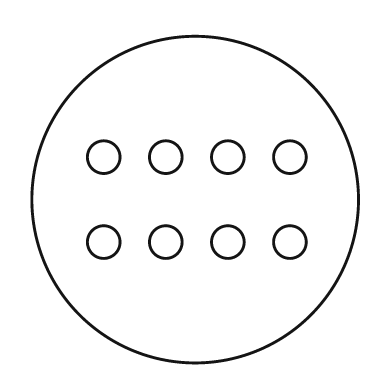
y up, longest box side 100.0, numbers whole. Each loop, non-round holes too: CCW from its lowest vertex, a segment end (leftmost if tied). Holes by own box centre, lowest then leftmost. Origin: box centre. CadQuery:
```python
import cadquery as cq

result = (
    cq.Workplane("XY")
    .moveTo(0.0, 0.0)
    .circle(50.0)
    .moveTo(-28.0, -13.0)
    .circle(5.0)
    .moveTo(-9.0, -13.0)
    .circle(5.0)
    .moveTo(10.0, -13.0)
    .circle(5.0)
    .moveTo(29.0, -13.0)
    .circle(5.0)
    .moveTo(-28.0, 13.0)
    .circle(5.0)
    .moveTo(-9.0, 13.0)
    .circle(5.0)
    .moveTo(10.0, 13.0)
    .circle(5.0)
    .moveTo(29.0, 13.0)
    .circle(5.0)
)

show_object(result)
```